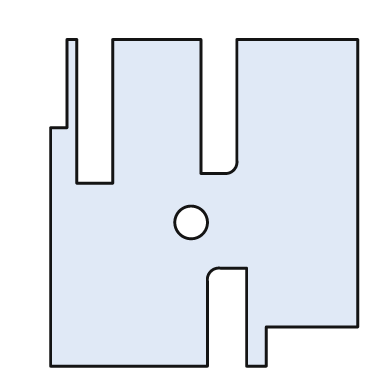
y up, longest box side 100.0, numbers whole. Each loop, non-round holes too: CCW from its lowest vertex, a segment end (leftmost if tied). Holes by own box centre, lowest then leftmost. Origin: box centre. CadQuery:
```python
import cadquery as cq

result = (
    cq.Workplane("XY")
    .moveTo(-47.0, -50.0)
    .lineTo(1.0, -50.0)
    .lineTo(1.0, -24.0)
    .threePointArc((2.0, -21.0), (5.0, -20.0))
    .lineTo(13.0, -20.0)
    .lineTo(13.0, -50.0)
    .lineTo(19.0, -50.0)
    .lineTo(19.0, -38.0)
    .lineTo(47.0, -38.0)
    .lineTo(47.0, 50.0)
    .lineTo(10.0, 50.0)
    .lineTo(10.0, 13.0)
    .threePointArc((9.0, 10.0), (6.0, 9.0))
    .lineTo(-1.0, 9.0)
    .lineTo(-1.0, 50.0)
    .lineTo(-28.0, 50.0)
    .lineTo(-28.0, 6.0)
    .lineTo(-39.0, 6.0)
    .lineTo(-39.0, 50.0)
    .lineTo(-42.0, 50.0)
    .lineTo(-42.0, 23.0)
    .lineTo(-47.0, 23.0)
    .close()
    .moveTo(-4.0, -6.0)
    .circle(5.0)
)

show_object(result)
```